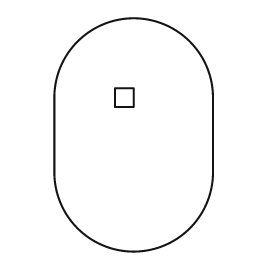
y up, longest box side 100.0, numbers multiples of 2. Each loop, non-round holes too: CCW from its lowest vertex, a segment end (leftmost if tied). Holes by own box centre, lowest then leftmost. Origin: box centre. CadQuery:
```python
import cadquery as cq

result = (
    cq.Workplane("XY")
    .moveTo(-34.0, -16.0)
    .threePointArc((0.0, -50.0), (34.0, -16.0))
    .lineTo(34.0, 16.0)
    .threePointArc((0.0, 50.0), (-34.0, 16.0))
    .close()
    .moveTo(-8.0, 12.0)
    .lineTo(0.0, 12.0)
    .lineTo(0.0, 20.0)
    .lineTo(-8.0, 20.0)
    .close()
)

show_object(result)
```